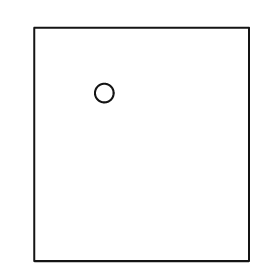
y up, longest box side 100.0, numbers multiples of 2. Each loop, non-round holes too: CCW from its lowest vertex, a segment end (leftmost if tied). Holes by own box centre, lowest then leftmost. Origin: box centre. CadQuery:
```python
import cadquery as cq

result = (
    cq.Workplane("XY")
    .moveTo(-46.0, -50.0)
    .lineTo(46.0, -50.0)
    .lineTo(46.0, 50.0)
    .lineTo(-46.0, 50.0)
    .close()
    .moveTo(-16.0, 22.0)
    .circle(4.0)
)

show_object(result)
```